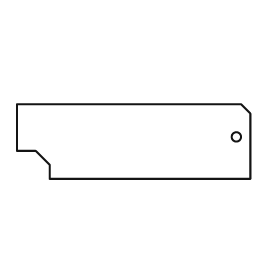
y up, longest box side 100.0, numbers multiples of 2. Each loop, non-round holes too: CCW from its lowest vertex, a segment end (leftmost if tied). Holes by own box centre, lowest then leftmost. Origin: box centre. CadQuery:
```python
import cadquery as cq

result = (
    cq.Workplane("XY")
    .moveTo(-36.0, -16.0)
    .lineTo(50.0, -16.0)
    .lineTo(50.0, 12.0)
    .lineTo(46.0, 16.0)
    .lineTo(-50.0, 16.0)
    .lineTo(-50.0, -4.0)
    .lineTo(-42.0, -4.0)
    .lineTo(-36.0, -10.0)
    .close()
    .moveTo(44.0, 2.0)
    .circle(2.0)
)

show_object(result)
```